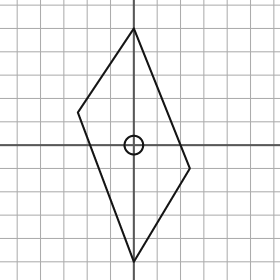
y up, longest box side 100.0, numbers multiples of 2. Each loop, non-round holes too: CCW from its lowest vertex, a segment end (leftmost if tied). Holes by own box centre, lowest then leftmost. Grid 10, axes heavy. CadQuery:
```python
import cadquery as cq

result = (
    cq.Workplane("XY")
    .moveTo(0.0, -50.0)
    .lineTo(24.0, -10.0)
    .lineTo(0.0, 50.0)
    .lineTo(-24.0, 14.0)
    .close()
    .moveTo(0.0, 0.0)
    .circle(4.0)
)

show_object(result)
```